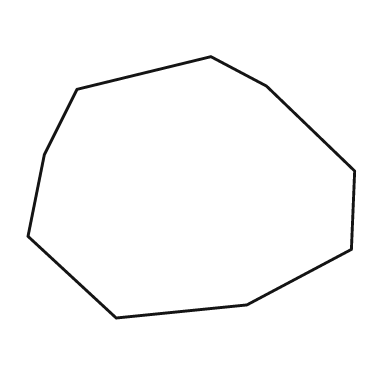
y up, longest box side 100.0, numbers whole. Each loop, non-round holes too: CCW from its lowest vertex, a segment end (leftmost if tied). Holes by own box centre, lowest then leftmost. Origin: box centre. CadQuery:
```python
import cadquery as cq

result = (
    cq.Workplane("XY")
    .moveTo(-23.0, -40.0)
    .lineTo(17.0, -36.0)
    .lineTo(49.0, -19.0)
    .lineTo(50.0, 5.0)
    .lineTo(23.0, 31.0)
    .lineTo(6.0, 40.0)
    .lineTo(-35.0, 30.0)
    .lineTo(-45.0, 10.0)
    .lineTo(-50.0, -15.0)
    .close()
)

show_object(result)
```